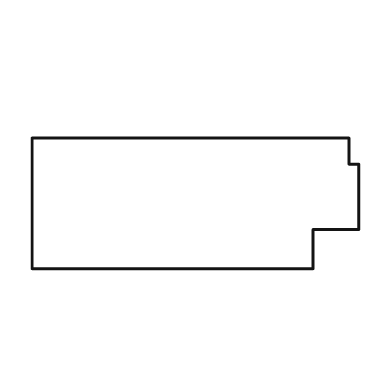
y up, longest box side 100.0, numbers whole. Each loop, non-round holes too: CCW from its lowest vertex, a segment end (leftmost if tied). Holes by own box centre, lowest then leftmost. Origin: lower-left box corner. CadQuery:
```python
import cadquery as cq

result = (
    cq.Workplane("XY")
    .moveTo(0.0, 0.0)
    .lineTo(86.0, 0.0)
    .lineTo(86.0, 12.0)
    .lineTo(100.0, 12.0)
    .lineTo(100.0, 32.0)
    .lineTo(97.0, 32.0)
    .lineTo(97.0, 40.0)
    .lineTo(0.0, 40.0)
    .close()
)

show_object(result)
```